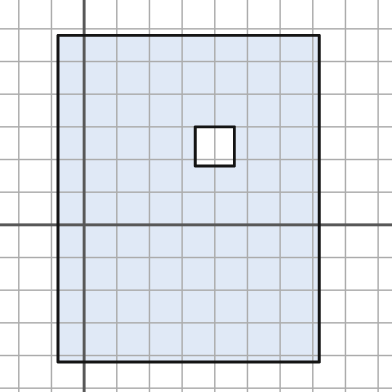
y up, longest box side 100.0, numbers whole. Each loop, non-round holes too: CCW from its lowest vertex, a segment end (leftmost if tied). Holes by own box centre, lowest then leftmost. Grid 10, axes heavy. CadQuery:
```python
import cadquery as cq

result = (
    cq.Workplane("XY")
    .moveTo(-8.0, -42.0)
    .lineTo(72.0, -42.0)
    .lineTo(72.0, 58.0)
    .lineTo(-8.0, 58.0)
    .close()
    .moveTo(34.0, 18.0)
    .lineTo(46.0, 18.0)
    .lineTo(46.0, 30.0)
    .lineTo(34.0, 30.0)
    .close()
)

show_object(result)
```